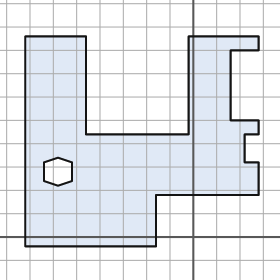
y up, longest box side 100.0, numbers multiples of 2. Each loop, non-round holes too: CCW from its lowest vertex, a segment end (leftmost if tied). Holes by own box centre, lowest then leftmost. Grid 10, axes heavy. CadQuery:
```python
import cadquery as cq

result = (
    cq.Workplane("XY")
    .moveTo(-72.0, -4.0)
    .lineTo(-16.0, -4.0)
    .lineTo(-16.0, 18.0)
    .lineTo(28.0, 18.0)
    .lineTo(28.0, 32.0)
    .lineTo(22.0, 32.0)
    .lineTo(22.0, 44.0)
    .lineTo(28.0, 44.0)
    .lineTo(28.0, 50.0)
    .lineTo(16.0, 50.0)
    .lineTo(16.0, 80.0)
    .lineTo(28.0, 80.0)
    .lineTo(28.0, 86.0)
    .lineTo(-2.0, 86.0)
    .lineTo(-2.0, 44.0)
    .lineTo(-46.0, 44.0)
    .lineTo(-46.0, 86.0)
    .lineTo(-72.0, 86.0)
    .close()
    .moveTo(-58.0, 22.0)
    .lineTo(-52.0, 24.0)
    .lineTo(-52.0, 32.0)
    .lineTo(-58.0, 34.0)
    .lineTo(-64.0, 32.0)
    .lineTo(-64.0, 24.0)
    .close()
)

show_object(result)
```